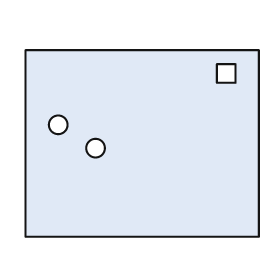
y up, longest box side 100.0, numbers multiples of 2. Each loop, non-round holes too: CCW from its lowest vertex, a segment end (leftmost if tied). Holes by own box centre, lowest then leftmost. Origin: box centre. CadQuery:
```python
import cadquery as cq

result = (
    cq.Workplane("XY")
    .moveTo(-50.0, -40.0)
    .lineTo(50.0, -40.0)
    .lineTo(50.0, 40.0)
    .lineTo(-50.0, 40.0)
    .close()
    .moveTo(-20.0, -2.0)
    .circle(4.0)
    .moveTo(-36.0, 8.0)
    .circle(4.0)
    .moveTo(32.0, 26.0)
    .lineTo(40.0, 26.0)
    .lineTo(40.0, 34.0)
    .lineTo(32.0, 34.0)
    .close()
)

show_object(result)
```